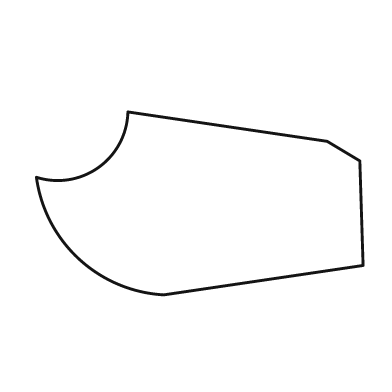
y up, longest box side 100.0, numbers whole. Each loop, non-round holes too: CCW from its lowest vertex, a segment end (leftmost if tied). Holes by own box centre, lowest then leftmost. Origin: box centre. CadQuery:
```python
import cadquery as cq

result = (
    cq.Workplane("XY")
    .moveTo(-11.0, -28.0)
    .lineTo(50.0, -19.0)
    .lineTo(49.0, 13.0)
    .lineTo(39.0, 19.0)
    .lineTo(-22.0, 28.0)
    .threePointArc((-31.0, 11.0), (-50.0, 8.0))
    .threePointArc((-37.0, -17.0), (-11.0, -28.0))
    .close()
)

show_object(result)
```